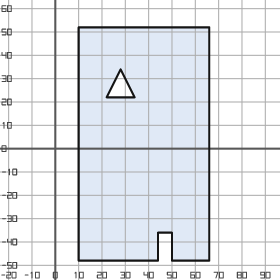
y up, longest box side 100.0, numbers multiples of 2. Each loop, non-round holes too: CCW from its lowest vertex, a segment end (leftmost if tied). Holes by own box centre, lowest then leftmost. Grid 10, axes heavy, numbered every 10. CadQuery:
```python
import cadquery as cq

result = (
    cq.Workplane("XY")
    .moveTo(10.0, -48.0)
    .lineTo(44.0, -48.0)
    .lineTo(44.0, -36.0)
    .lineTo(50.0, -36.0)
    .lineTo(50.0, -48.0)
    .lineTo(66.0, -48.0)
    .lineTo(66.0, 52.0)
    .lineTo(10.0, 52.0)
    .close()
    .moveTo(22.0, 22.0)
    .lineTo(34.0, 22.0)
    .lineTo(28.0, 34.0)
    .close()
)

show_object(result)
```